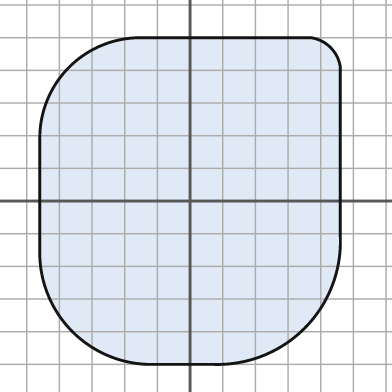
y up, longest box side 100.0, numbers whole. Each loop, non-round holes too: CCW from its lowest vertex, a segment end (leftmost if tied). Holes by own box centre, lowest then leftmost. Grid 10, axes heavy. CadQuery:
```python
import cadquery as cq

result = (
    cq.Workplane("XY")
    .moveTo(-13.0, -50.0)
    .lineTo(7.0, -50.0)
    .threePointArc((35.0, -39.0), (46.0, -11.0))
    .lineTo(46.0, 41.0)
    .threePointArc((43.0, 47.0), (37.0, 50.0))
    .lineTo(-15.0, 50.0)
    .threePointArc((-37.0, 41.0), (-46.0, 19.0))
    .lineTo(-46.0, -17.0)
    .threePointArc((-36.0, -40.0), (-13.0, -50.0))
    .close()
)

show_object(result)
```